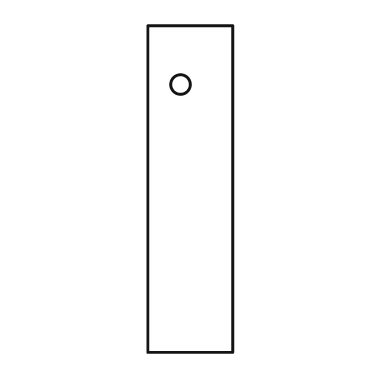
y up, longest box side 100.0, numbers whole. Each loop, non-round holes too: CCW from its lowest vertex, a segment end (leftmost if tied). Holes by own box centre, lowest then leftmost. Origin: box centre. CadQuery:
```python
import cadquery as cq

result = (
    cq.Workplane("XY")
    .moveTo(-13.0, -50.0)
    .lineTo(13.0, -50.0)
    .lineTo(13.0, 50.0)
    .lineTo(-13.0, 50.0)
    .close()
    .moveTo(-3.0, 32.0)
    .circle(3.0)
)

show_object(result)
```